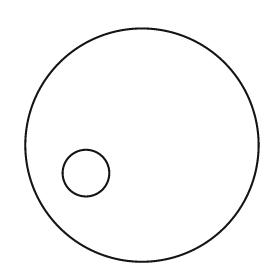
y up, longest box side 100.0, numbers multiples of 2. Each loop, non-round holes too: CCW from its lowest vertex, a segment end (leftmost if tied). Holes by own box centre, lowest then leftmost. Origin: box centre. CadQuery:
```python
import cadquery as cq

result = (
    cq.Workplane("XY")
    .moveTo(0.0, 0.0)
    .circle(50.0)
    .moveTo(-24.0, -12.0)
    .circle(10.0)
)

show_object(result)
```